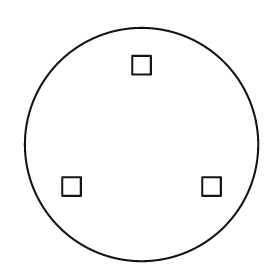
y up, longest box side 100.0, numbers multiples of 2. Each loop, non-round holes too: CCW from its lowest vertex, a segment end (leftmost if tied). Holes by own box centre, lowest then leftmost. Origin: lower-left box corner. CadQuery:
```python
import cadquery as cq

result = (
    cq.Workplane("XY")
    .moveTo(50.0, 50.0)
    .circle(50.0)
    .moveTo(16.0, 28.0)
    .lineTo(24.0, 28.0)
    .lineTo(24.0, 36.0)
    .lineTo(16.0, 36.0)
    .close()
    .moveTo(76.0, 28.0)
    .lineTo(84.0, 28.0)
    .lineTo(84.0, 36.0)
    .lineTo(76.0, 36.0)
    .close()
    .moveTo(46.0, 80.0)
    .lineTo(54.0, 80.0)
    .lineTo(54.0, 88.0)
    .lineTo(46.0, 88.0)
    .close()
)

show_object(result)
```